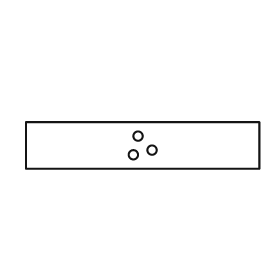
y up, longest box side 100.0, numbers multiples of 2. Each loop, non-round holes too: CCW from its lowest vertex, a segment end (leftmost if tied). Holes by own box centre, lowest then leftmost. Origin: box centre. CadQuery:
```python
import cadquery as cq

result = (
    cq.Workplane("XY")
    .moveTo(-50.0, -10.0)
    .lineTo(50.0, -10.0)
    .lineTo(50.0, 10.0)
    .lineTo(-50.0, 10.0)
    .close()
    .moveTo(-4.0, -4.0)
    .circle(2.0)
    .moveTo(4.0, -2.0)
    .circle(2.0)
    .moveTo(-2.0, 4.0)
    .circle(2.0)
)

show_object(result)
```